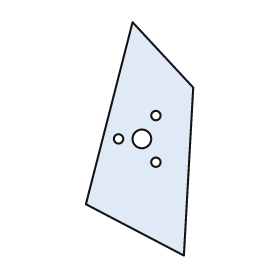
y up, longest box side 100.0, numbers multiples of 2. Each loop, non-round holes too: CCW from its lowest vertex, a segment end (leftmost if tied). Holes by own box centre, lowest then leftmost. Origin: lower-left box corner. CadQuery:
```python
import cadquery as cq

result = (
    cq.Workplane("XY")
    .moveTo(42.0, 0.0)
    .lineTo(46.0, 72.0)
    .lineTo(20.0, 100.0)
    .lineTo(0.0, 22.0)
    .close()
    .moveTo(30.0, 40.0)
    .circle(2.0)
    .moveTo(14.0, 50.0)
    .circle(2.0)
    .moveTo(24.0, 50.0)
    .circle(4.0)
    .moveTo(30.0, 60.0)
    .circle(2.0)
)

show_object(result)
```